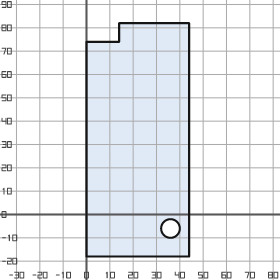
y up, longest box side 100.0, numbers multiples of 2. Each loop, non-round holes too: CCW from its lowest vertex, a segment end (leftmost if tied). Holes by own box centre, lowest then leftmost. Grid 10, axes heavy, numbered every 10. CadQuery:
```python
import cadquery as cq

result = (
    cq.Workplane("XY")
    .moveTo(0.0, -18.0)
    .lineTo(44.0, -18.0)
    .lineTo(44.0, 82.0)
    .lineTo(14.0, 82.0)
    .lineTo(14.0, 74.0)
    .lineTo(0.0, 74.0)
    .close()
    .moveTo(36.0, -6.0)
    .circle(4.0)
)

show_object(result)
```